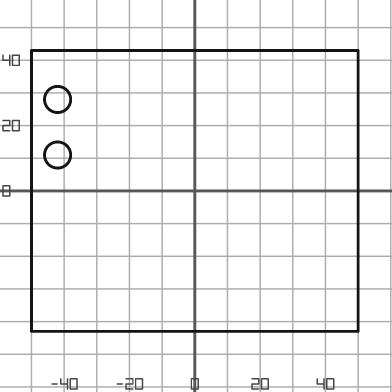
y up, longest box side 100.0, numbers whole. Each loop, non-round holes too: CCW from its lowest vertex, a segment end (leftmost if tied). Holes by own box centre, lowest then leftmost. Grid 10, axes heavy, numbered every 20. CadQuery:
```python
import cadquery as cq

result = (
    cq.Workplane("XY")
    .moveTo(-50.0, -43.0)
    .lineTo(50.0, -43.0)
    .lineTo(50.0, 43.0)
    .lineTo(-50.0, 43.0)
    .close()
    .moveTo(-42.0, 11.0)
    .circle(4.0)
    .moveTo(-42.0, 28.0)
    .circle(4.0)
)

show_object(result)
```